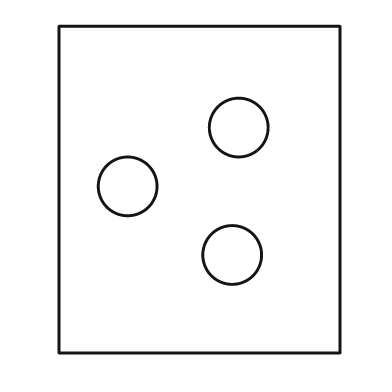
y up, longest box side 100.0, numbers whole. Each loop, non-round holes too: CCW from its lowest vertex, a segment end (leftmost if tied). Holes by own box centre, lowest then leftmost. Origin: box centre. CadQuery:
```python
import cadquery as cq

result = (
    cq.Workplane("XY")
    .moveTo(-43.0, -50.0)
    .lineTo(43.0, -50.0)
    .lineTo(43.0, 50.0)
    .lineTo(-43.0, 50.0)
    .close()
    .moveTo(10.0, -20.0)
    .circle(9.0)
    .moveTo(-22.0, 1.0)
    .circle(9.0)
    .moveTo(12.0, 19.0)
    .circle(9.0)
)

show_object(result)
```